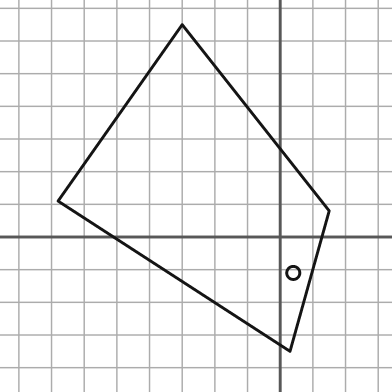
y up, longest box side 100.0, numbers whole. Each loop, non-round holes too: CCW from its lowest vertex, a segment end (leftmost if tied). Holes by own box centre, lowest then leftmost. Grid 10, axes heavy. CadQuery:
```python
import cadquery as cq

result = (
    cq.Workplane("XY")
    .moveTo(3.0, -35.0)
    .lineTo(15.0, 8.0)
    .lineTo(-30.0, 65.0)
    .lineTo(-68.0, 11.0)
    .close()
    .moveTo(4.0, -11.0)
    .circle(2.0)
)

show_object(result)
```